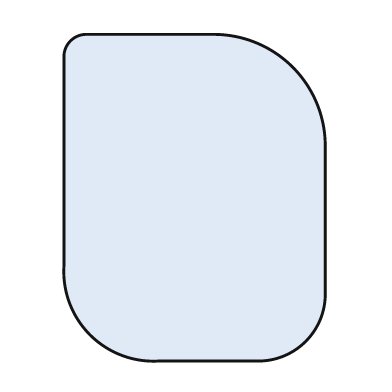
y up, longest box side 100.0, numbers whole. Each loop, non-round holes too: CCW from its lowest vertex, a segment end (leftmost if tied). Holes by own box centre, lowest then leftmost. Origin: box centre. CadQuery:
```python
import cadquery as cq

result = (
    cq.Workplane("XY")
    .moveTo(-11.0, -50.0)
    .lineTo(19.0, -50.0)
    .threePointArc((34.0, -44.0), (40.0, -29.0))
    .lineTo(40.0, 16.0)
    .threePointArc((30.0, 40.0), (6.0, 50.0))
    .lineTo(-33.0, 50.0)
    .threePointArc((-38.0, 48.0), (-40.0, 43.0))
    .lineTo(-40.0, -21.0)
    .threePointArc((-32.0, -42.0), (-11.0, -50.0))
    .close()
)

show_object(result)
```